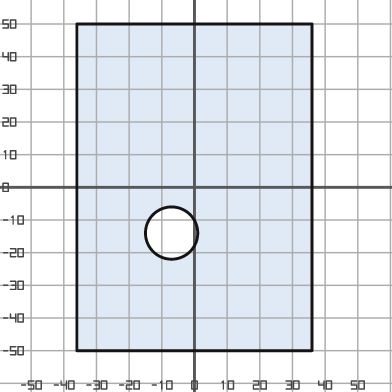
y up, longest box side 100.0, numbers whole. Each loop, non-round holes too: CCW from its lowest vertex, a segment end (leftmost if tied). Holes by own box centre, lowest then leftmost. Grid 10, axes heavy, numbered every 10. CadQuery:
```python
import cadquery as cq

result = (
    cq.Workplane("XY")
    .moveTo(-36.0, -50.0)
    .lineTo(36.0, -50.0)
    .lineTo(36.0, 50.0)
    .lineTo(-36.0, 50.0)
    .close()
    .moveTo(-7.0, -14.0)
    .circle(8.0)
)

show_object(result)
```